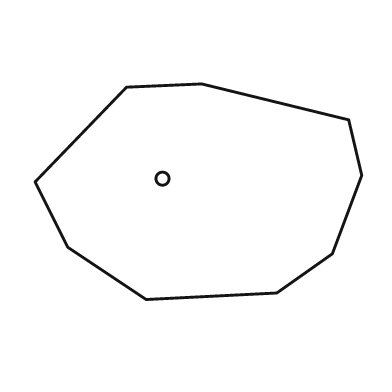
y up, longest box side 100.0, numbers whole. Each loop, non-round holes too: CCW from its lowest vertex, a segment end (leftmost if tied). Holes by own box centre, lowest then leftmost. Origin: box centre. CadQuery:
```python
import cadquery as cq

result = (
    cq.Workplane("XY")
    .moveTo(-16.0, -33.0)
    .lineTo(24.0, -31.0)
    .lineTo(41.0, -19.0)
    .lineTo(50.0, 5.0)
    .lineTo(46.0, 22.0)
    .lineTo(1.0, 33.0)
    .lineTo(-22.0, 32.0)
    .lineTo(-50.0, 3.0)
    .lineTo(-40.0, -17.0)
    .close()
    .moveTo(-11.0, 4.0)
    .circle(2.0)
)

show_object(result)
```